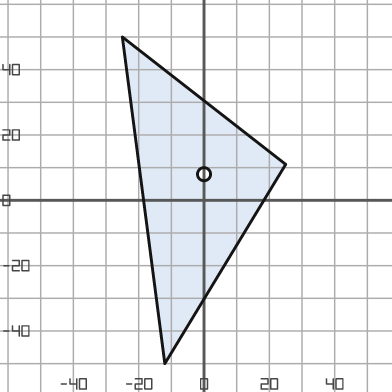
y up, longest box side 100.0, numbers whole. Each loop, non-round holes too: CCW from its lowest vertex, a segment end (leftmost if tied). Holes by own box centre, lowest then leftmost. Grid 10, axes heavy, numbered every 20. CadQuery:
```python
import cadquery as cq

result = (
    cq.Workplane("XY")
    .moveTo(-12.0, -50.0)
    .lineTo(25.0, 11.0)
    .lineTo(-25.0, 50.0)
    .close()
    .moveTo(0.0, 8.0)
    .circle(2.0)
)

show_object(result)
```